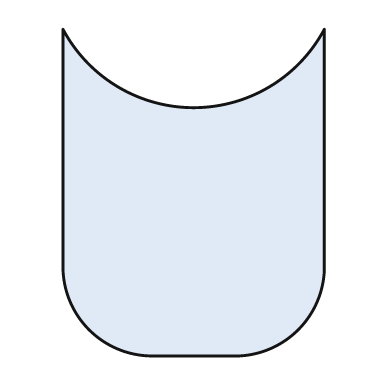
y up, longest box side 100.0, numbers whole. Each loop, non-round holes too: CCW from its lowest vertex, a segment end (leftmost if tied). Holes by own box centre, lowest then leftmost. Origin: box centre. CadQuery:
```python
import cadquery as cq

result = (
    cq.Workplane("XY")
    .moveTo(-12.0, -50.0)
    .lineTo(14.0, -50.0)
    .threePointArc((32.0, -42.0), (40.0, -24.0))
    .lineTo(40.0, 50.0)
    .threePointArc((0.0, 26.0), (-40.0, 50.0))
    .lineTo(-40.0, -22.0)
    .threePointArc((-32.0, -42.0), (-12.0, -50.0))
    .close()
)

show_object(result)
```